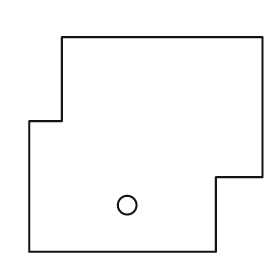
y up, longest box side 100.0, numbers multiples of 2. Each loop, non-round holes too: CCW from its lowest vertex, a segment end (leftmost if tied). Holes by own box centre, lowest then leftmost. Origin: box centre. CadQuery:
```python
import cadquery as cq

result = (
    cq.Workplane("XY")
    .moveTo(-50.0, -46.0)
    .lineTo(30.0, -46.0)
    .lineTo(30.0, -14.0)
    .lineTo(50.0, -14.0)
    .lineTo(50.0, 46.0)
    .lineTo(-36.0, 46.0)
    .lineTo(-36.0, 10.0)
    .lineTo(-50.0, 10.0)
    .close()
    .moveTo(-8.0, -26.0)
    .circle(4.0)
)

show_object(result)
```